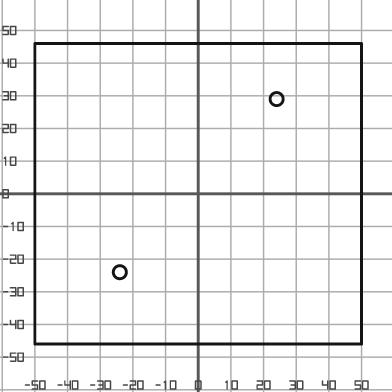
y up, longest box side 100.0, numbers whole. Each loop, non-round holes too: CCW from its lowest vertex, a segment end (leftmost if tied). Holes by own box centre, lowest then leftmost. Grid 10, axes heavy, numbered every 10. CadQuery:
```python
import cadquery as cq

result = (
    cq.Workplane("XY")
    .moveTo(-50.0, -46.0)
    .lineTo(50.0, -46.0)
    .lineTo(50.0, 46.0)
    .lineTo(-50.0, 46.0)
    .close()
    .moveTo(-24.0, -24.0)
    .circle(2.0)
    .moveTo(24.0, 29.0)
    .circle(2.0)
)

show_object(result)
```